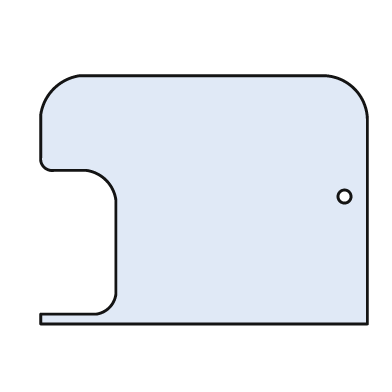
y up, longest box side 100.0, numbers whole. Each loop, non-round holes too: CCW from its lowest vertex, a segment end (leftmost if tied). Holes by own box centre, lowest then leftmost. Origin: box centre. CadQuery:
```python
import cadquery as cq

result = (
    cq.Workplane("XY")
    .moveTo(-50.0, -38.0)
    .lineTo(50.0, -38.0)
    .lineTo(50.0, 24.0)
    .threePointArc((46.0, 34.0), (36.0, 38.0))
    .lineTo(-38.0, 38.0)
    .threePointArc((-46.0, 34.0), (-50.0, 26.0))
    .lineTo(-50.0, 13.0)
    .threePointArc((-49.0, 10.0), (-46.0, 9.0))
    .lineTo(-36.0, 9.0)
    .threePointArc((-30.0, 6.0), (-27.0, 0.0))
    .lineTo(-27.0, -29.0)
    .threePointArc((-29.0, -33.0), (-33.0, -35.0))
    .lineTo(-50.0, -35.0)
    .close()
    .moveTo(43.0, 1.0)
    .circle(2.0)
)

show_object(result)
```